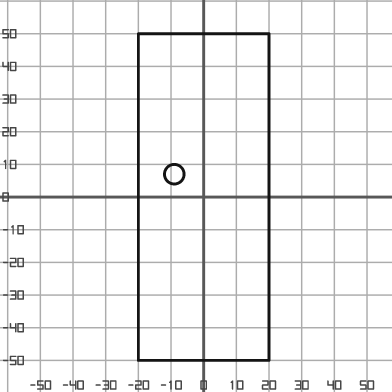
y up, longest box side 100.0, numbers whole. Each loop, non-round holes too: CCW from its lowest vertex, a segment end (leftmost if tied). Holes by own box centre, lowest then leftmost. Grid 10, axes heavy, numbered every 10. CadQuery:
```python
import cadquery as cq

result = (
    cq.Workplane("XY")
    .moveTo(-20.0, -50.0)
    .lineTo(20.0, -50.0)
    .lineTo(20.0, 50.0)
    .lineTo(-20.0, 50.0)
    .close()
    .moveTo(-9.0, 7.0)
    .circle(3.0)
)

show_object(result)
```